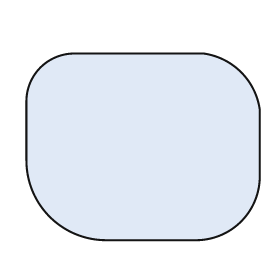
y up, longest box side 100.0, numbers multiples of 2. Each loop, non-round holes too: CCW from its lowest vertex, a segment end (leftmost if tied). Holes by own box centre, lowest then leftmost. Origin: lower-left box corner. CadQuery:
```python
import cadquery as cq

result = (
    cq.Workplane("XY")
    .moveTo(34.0, 0.0)
    .lineTo(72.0, 0.0)
    .threePointArc((92.0, 8.0), (100.0, 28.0))
    .lineTo(100.0, 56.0)
    .threePointArc((92.0, 72.0), (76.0, 80.0))
    .lineTo(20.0, 80.0)
    .threePointArc((6.0, 74.0), (0.0, 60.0))
    .lineTo(0.0, 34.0)
    .threePointArc((10.0, 10.0), (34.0, 0.0))
    .close()
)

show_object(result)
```